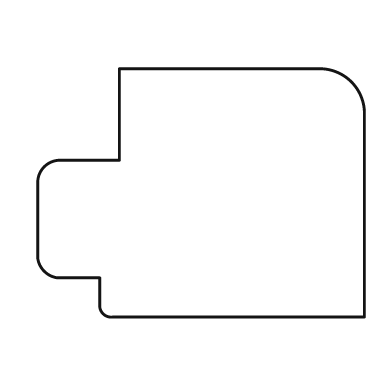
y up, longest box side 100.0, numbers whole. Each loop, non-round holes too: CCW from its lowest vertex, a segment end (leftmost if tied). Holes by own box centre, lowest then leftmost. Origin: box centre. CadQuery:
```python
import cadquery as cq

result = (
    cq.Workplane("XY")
    .moveTo(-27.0, -38.0)
    .lineTo(50.0, -38.0)
    .lineTo(50.0, 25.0)
    .threePointArc((46.0, 34.0), (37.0, 38.0))
    .lineTo(-25.0, 38.0)
    .lineTo(-25.0, 10.0)
    .lineTo(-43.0, 10.0)
    .threePointArc((-48.0, 8.0), (-50.0, 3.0))
    .lineTo(-50.0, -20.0)
    .threePointArc((-48.0, -24.0), (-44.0, -26.0))
    .lineTo(-31.0, -26.0)
    .lineTo(-31.0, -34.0)
    .threePointArc((-30.0, -37.0), (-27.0, -38.0))
    .close()
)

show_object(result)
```